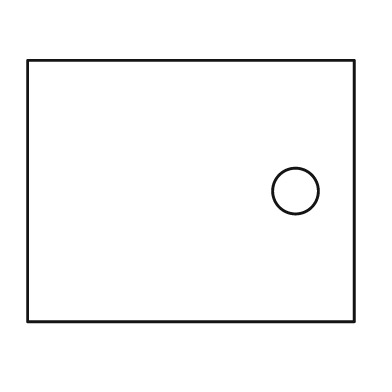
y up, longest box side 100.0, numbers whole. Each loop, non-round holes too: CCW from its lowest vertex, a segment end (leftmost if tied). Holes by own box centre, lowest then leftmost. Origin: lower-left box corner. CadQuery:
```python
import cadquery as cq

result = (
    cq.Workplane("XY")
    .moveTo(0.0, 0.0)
    .lineTo(100.0, 0.0)
    .lineTo(100.0, 80.0)
    .lineTo(0.0, 80.0)
    .close()
    .moveTo(82.0, 40.0)
    .circle(7.0)
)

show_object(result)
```